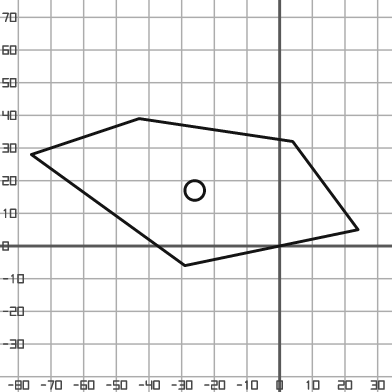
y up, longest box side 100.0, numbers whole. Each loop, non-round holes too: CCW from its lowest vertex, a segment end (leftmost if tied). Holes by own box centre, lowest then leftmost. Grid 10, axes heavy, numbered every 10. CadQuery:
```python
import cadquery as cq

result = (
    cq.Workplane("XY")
    .moveTo(-29.0, -6.0)
    .lineTo(24.0, 5.0)
    .lineTo(4.0, 32.0)
    .lineTo(-43.0, 39.0)
    .lineTo(-76.0, 28.0)
    .close()
    .moveTo(-26.0, 17.0)
    .circle(3.0)
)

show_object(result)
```